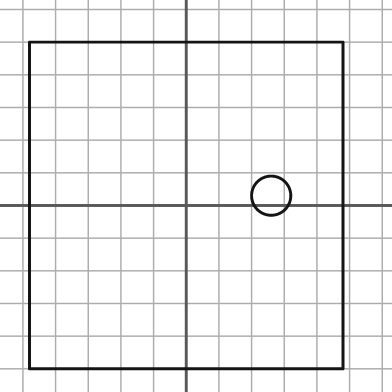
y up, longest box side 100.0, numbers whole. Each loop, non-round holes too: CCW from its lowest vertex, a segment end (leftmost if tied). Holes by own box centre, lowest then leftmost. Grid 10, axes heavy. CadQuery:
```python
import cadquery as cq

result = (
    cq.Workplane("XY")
    .moveTo(-48.0, -50.0)
    .lineTo(48.0, -50.0)
    .lineTo(48.0, 50.0)
    .lineTo(-48.0, 50.0)
    .close()
    .moveTo(26.0, 3.0)
    .circle(6.0)
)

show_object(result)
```